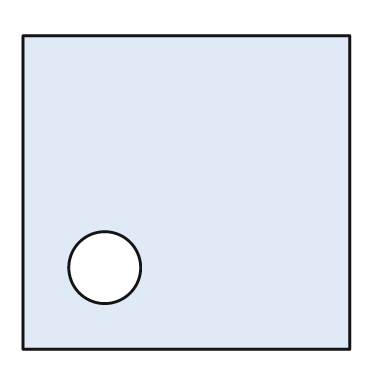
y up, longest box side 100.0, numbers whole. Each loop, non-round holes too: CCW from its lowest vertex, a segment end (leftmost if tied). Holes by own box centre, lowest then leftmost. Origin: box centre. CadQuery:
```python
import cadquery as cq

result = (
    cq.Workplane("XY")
    .moveTo(-50.0, -48.0)
    .lineTo(50.0, -48.0)
    .lineTo(50.0, 48.0)
    .lineTo(-50.0, 48.0)
    .close()
    .moveTo(-25.0, -23.0)
    .circle(11.0)
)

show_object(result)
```